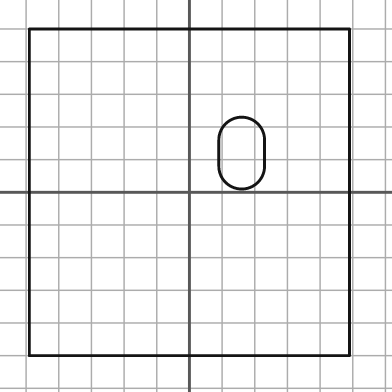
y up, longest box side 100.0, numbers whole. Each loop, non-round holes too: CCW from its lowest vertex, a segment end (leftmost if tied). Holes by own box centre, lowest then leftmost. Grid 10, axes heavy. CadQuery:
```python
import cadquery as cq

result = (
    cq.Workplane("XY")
    .moveTo(-49.0, -50.0)
    .lineTo(49.0, -50.0)
    .lineTo(49.0, 50.0)
    .lineTo(-49.0, 50.0)
    .close()
    .moveTo(9.0, 8.0)
    .threePointArc((16.0, 1.0), (23.0, 8.0))
    .lineTo(23.0, 16.0)
    .threePointArc((16.0, 23.0), (9.0, 16.0))
    .close()
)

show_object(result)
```